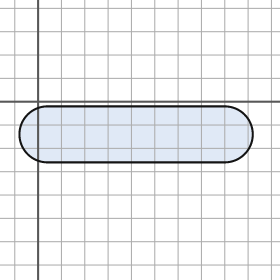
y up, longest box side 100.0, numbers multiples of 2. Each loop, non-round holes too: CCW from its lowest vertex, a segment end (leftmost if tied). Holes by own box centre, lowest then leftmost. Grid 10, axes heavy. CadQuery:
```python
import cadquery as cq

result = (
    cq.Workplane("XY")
    .moveTo(4.0, -26.0)
    .lineTo(80.0, -26.0)
    .threePointArc((92.0, -14.0), (80.0, -2.0))
    .lineTo(4.0, -2.0)
    .threePointArc((-8.0, -14.0), (4.0, -26.0))
    .close()
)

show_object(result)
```